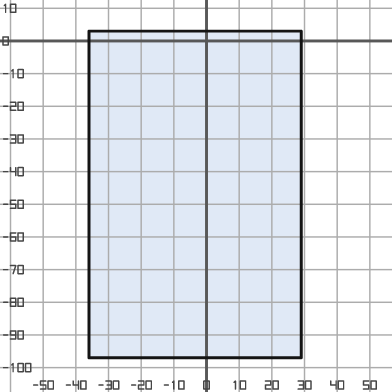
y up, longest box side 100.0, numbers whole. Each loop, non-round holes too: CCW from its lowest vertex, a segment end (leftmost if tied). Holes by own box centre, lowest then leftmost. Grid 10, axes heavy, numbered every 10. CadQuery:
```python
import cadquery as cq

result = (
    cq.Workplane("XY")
    .moveTo(-36.0, -97.0)
    .lineTo(29.0, -97.0)
    .lineTo(29.0, 3.0)
    .lineTo(-36.0, 3.0)
    .close()
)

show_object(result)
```